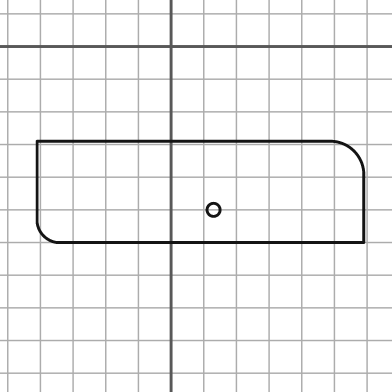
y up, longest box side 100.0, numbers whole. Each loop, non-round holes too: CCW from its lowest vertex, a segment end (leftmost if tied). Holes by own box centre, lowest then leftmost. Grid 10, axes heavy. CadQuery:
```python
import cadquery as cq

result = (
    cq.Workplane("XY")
    .moveTo(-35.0, -60.0)
    .lineTo(59.0, -60.0)
    .lineTo(59.0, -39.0)
    .threePointArc((56.0, -32.0), (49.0, -29.0))
    .lineTo(-41.0, -29.0)
    .lineTo(-41.0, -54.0)
    .threePointArc((-39.0, -58.0), (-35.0, -60.0))
    .close()
    .moveTo(13.0, -50.0)
    .circle(2.0)
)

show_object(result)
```